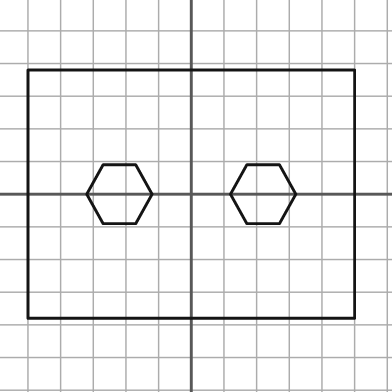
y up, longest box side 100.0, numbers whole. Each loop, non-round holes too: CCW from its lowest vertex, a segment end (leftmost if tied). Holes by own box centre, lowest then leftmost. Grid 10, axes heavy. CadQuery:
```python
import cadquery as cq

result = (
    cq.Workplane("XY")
    .moveTo(-50.0, -38.0)
    .lineTo(50.0, -38.0)
    .lineTo(50.0, 38.0)
    .lineTo(-50.0, 38.0)
    .close()
    .moveTo(-27.0, -9.0)
    .lineTo(-17.0, -9.0)
    .lineTo(-12.0, 0.0)
    .lineTo(-17.0, 9.0)
    .lineTo(-27.0, 9.0)
    .lineTo(-32.0, 0.0)
    .close()
    .moveTo(17.0, -9.0)
    .lineTo(27.0, -9.0)
    .lineTo(32.0, 0.0)
    .lineTo(27.0, 9.0)
    .lineTo(17.0, 9.0)
    .lineTo(12.0, 0.0)
    .close()
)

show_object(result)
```